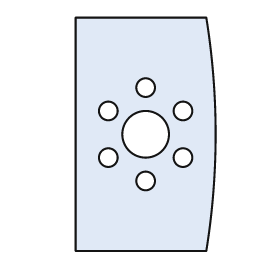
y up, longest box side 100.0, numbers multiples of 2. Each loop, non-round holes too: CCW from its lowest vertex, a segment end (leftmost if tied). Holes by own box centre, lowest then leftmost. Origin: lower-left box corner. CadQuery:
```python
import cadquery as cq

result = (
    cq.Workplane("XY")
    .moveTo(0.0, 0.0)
    .lineTo(56.0, 0.0)
    .threePointArc((60.0, 50.0), (56.0, 100.0))
    .lineTo(0.0, 100.0)
    .close()
    .moveTo(30.0, 30.0)
    .circle(4.0)
    .moveTo(14.0, 40.0)
    .circle(4.0)
    .moveTo(46.0, 40.0)
    .circle(4.0)
    .moveTo(30.0, 50.0)
    .circle(10.0)
    .moveTo(14.0, 60.0)
    .circle(4.0)
    .moveTo(46.0, 60.0)
    .circle(4.0)
    .moveTo(30.0, 70.0)
    .circle(4.0)
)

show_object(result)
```